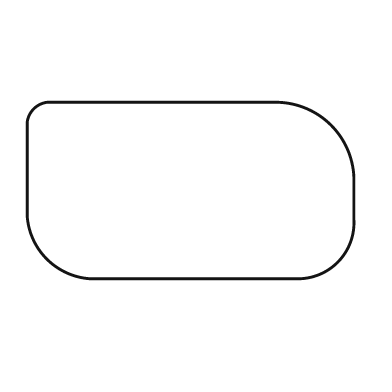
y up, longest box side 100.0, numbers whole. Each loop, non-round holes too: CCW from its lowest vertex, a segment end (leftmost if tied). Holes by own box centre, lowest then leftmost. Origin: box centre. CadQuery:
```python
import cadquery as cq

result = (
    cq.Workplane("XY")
    .moveTo(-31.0, -27.0)
    .lineTo(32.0, -27.0)
    .threePointArc((45.0, -22.0), (50.0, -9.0))
    .lineTo(50.0, 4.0)
    .threePointArc((43.0, 20.0), (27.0, 27.0))
    .lineTo(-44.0, 27.0)
    .threePointArc((-48.0, 25.0), (-50.0, 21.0))
    .lineTo(-50.0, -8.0)
    .threePointArc((-44.0, -21.0), (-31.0, -27.0))
    .close()
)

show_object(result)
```